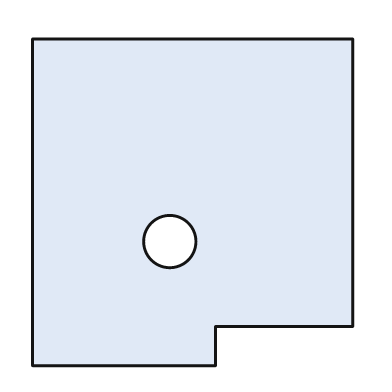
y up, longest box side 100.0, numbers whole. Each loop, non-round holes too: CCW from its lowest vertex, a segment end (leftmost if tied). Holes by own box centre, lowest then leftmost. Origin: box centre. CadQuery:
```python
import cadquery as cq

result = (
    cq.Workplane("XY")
    .moveTo(-49.0, -50.0)
    .lineTo(7.0, -50.0)
    .lineTo(7.0, -38.0)
    .lineTo(49.0, -38.0)
    .lineTo(49.0, 50.0)
    .lineTo(-49.0, 50.0)
    .close()
    .moveTo(-7.0, -12.0)
    .circle(8.0)
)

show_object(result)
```